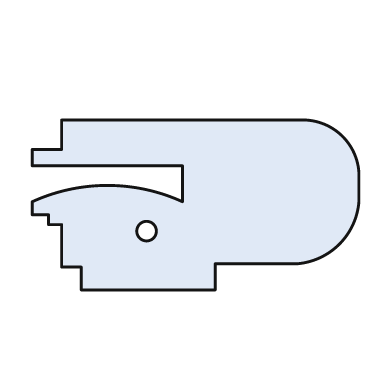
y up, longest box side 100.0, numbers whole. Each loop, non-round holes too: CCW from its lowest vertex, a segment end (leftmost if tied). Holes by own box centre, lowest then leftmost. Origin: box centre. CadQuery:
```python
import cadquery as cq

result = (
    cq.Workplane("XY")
    .moveTo(-35.0, -26.0)
    .lineTo(6.0, -26.0)
    .lineTo(6.0, -18.0)
    .lineTo(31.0, -18.0)
    .threePointArc((44.0, -12.0), (50.0, 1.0))
    .lineTo(50.0, 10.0)
    .threePointArc((45.0, 21.0), (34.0, 26.0))
    .lineTo(-41.0, 26.0)
    .lineTo(-41.0, 17.0)
    .lineTo(-50.0, 17.0)
    .lineTo(-50.0, 12.0)
    .lineTo(-4.0, 12.0)
    .lineTo(-4.0, 1.0)
    .threePointArc((-27.0, 6.0), (-50.0, 1.0))
    .lineTo(-50.0, -3.0)
    .lineTo(-45.0, -3.0)
    .lineTo(-45.0, -6.0)
    .lineTo(-41.0, -6.0)
    .lineTo(-41.0, -19.0)
    .lineTo(-35.0, -19.0)
    .close()
    .moveTo(-15.0, -8.0)
    .circle(3.0)
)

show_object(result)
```